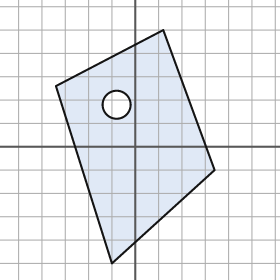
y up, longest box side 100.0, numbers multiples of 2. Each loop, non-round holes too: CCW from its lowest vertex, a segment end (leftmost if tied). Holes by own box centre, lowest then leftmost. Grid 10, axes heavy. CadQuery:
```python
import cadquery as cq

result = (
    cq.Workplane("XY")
    .moveTo(-10.0, -50.0)
    .lineTo(34.0, -10.0)
    .lineTo(12.0, 50.0)
    .lineTo(-34.0, 26.0)
    .close()
    .moveTo(-8.0, 18.0)
    .circle(6.0)
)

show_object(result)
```